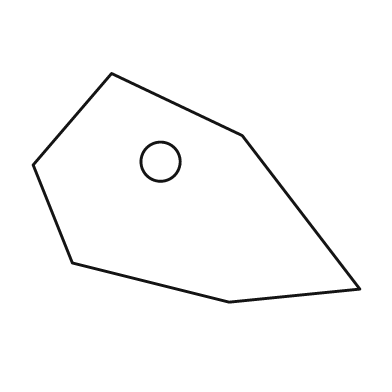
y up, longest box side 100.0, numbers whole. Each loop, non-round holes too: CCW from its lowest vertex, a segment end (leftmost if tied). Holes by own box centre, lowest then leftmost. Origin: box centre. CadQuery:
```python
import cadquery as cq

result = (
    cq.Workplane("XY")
    .moveTo(10.0, -35.0)
    .lineTo(50.0, -31.0)
    .lineTo(14.0, 16.0)
    .lineTo(-26.0, 35.0)
    .lineTo(-50.0, 7.0)
    .lineTo(-38.0, -23.0)
    .close()
    .moveTo(-11.0, 8.0)
    .circle(6.0)
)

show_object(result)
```